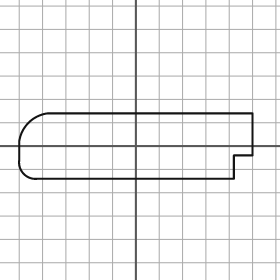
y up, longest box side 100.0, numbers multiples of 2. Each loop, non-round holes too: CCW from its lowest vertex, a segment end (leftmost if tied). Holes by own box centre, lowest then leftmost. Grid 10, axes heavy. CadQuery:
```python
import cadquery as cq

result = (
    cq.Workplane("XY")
    .moveTo(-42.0, -14.0)
    .lineTo(42.0, -14.0)
    .lineTo(42.0, -4.0)
    .lineTo(50.0, -4.0)
    .lineTo(50.0, 14.0)
    .lineTo(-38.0, 14.0)
    .threePointArc((-46.0, 10.0), (-50.0, 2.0))
    .lineTo(-50.0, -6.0)
    .threePointArc((-48.0, -12.0), (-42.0, -14.0))
    .close()
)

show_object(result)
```